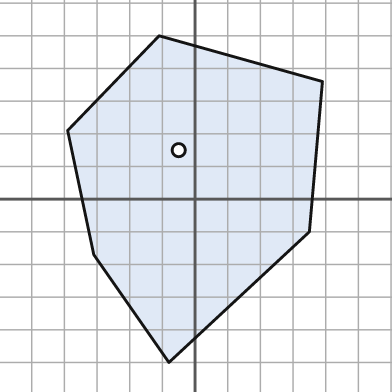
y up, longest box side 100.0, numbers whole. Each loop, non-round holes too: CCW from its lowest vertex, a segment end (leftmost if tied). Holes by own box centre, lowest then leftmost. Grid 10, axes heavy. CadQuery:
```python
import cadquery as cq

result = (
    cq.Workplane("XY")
    .moveTo(-8.0, -50.0)
    .lineTo(35.0, -10.0)
    .lineTo(39.0, 36.0)
    .lineTo(-11.0, 50.0)
    .lineTo(-39.0, 21.0)
    .lineTo(-31.0, -17.0)
    .close()
    .moveTo(-5.0, 15.0)
    .circle(2.0)
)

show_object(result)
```